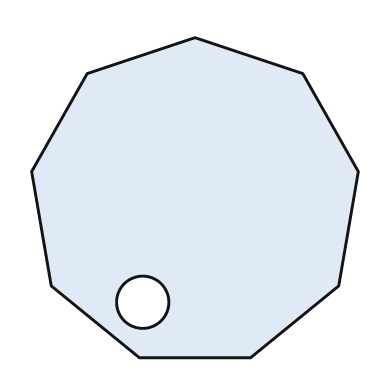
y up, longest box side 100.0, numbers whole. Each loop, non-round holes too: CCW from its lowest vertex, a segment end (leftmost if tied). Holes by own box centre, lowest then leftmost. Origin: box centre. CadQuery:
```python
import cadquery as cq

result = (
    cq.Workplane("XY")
    .moveTo(-17.0, -49.0)
    .lineTo(17.0, -49.0)
    .lineTo(44.0, -27.0)
    .lineTo(50.0, 8.0)
    .lineTo(33.0, 38.0)
    .lineTo(0.0, 49.0)
    .lineTo(-33.0, 38.0)
    .lineTo(-50.0, 8.0)
    .lineTo(-44.0, -27.0)
    .close()
    .moveTo(-16.0, -32.0)
    .circle(8.0)
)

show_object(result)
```